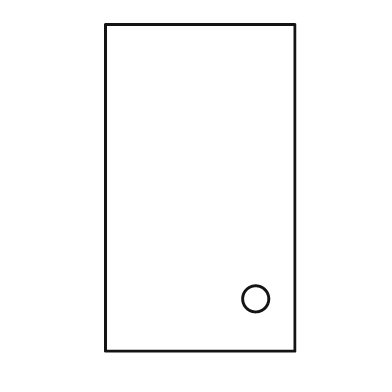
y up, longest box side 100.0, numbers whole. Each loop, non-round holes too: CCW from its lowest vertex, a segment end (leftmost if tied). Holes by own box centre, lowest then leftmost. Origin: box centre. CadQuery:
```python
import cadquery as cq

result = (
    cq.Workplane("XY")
    .moveTo(-29.0, -50.0)
    .lineTo(29.0, -50.0)
    .lineTo(29.0, 50.0)
    .lineTo(-29.0, 50.0)
    .close()
    .moveTo(17.0, -34.0)
    .circle(4.0)
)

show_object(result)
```